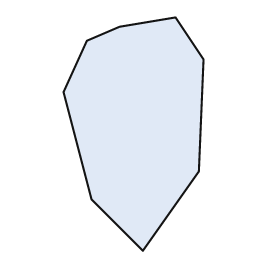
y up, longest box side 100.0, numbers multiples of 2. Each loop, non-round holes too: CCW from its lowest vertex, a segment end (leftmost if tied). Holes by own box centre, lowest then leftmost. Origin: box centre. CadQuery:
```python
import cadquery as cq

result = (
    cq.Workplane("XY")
    .moveTo(4.0, -50.0)
    .lineTo(28.0, -16.0)
    .lineTo(30.0, 32.0)
    .lineTo(18.0, 50.0)
    .lineTo(-6.0, 46.0)
    .lineTo(-20.0, 40.0)
    .lineTo(-30.0, 18.0)
    .lineTo(-18.0, -28.0)
    .close()
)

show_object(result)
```